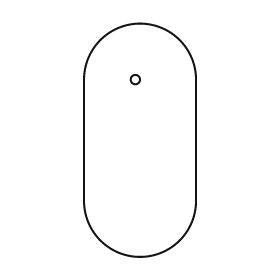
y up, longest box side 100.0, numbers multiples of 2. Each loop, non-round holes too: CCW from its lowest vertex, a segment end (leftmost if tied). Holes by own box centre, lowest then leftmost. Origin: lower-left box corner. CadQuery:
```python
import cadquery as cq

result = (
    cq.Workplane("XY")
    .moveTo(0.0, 24.0)
    .threePointArc((24.0, 0.0), (48.0, 24.0))
    .lineTo(48.0, 76.0)
    .threePointArc((24.0, 100.0), (0.0, 76.0))
    .close()
    .moveTo(22.0, 76.0)
    .circle(2.0)
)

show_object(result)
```